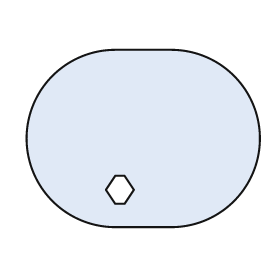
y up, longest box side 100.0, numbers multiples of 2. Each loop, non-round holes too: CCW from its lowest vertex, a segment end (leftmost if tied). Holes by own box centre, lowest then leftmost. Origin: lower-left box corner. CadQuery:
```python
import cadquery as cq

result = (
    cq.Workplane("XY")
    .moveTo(38.0, 0.0)
    .lineTo(62.0, 0.0)
    .threePointArc((100.0, 38.0), (62.0, 76.0))
    .lineTo(38.0, 76.0)
    .threePointArc((0.0, 38.0), (38.0, 0.0))
    .close()
    .moveTo(38.0, 10.0)
    .lineTo(42.0, 10.0)
    .lineTo(46.0, 16.0)
    .lineTo(42.0, 22.0)
    .lineTo(38.0, 22.0)
    .lineTo(34.0, 16.0)
    .close()
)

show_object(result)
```